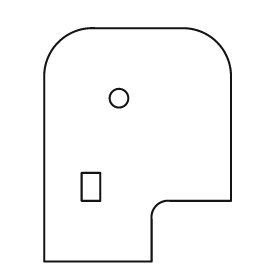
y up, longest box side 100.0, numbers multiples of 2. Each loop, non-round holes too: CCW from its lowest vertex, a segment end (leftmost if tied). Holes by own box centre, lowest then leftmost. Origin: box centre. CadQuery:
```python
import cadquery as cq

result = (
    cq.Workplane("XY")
    .moveTo(-40.0, -50.0)
    .lineTo(6.0, -50.0)
    .lineTo(6.0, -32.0)
    .threePointArc((8.0, -26.0), (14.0, -24.0))
    .lineTo(40.0, -24.0)
    .lineTo(40.0, 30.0)
    .threePointArc((34.0, 44.0), (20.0, 50.0))
    .lineTo(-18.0, 50.0)
    .threePointArc((-34.0, 44.0), (-40.0, 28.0))
    .close()
    .moveTo(-24.0, -24.0)
    .lineTo(-16.0, -24.0)
    .lineTo(-16.0, -12.0)
    .lineTo(-24.0, -12.0)
    .close()
    .moveTo(-8.0, 20.0)
    .circle(4.0)
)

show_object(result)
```